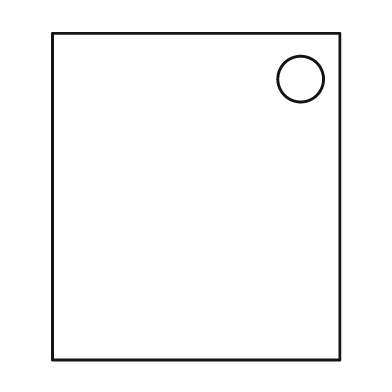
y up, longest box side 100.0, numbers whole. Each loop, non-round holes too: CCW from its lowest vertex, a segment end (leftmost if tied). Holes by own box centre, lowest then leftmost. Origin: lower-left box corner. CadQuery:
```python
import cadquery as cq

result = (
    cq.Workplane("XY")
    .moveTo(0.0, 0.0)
    .lineTo(88.0, 0.0)
    .lineTo(88.0, 100.0)
    .lineTo(0.0, 100.0)
    .close()
    .moveTo(76.0, 86.0)
    .circle(7.0)
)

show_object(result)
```